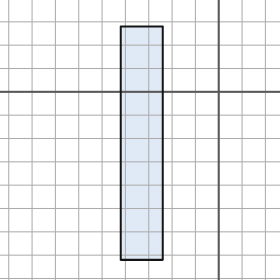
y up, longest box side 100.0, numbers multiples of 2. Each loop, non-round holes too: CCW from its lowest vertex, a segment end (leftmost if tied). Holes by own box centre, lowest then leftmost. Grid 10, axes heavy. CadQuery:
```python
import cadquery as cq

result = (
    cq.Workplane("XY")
    .moveTo(-42.0, -72.0)
    .lineTo(-24.0, -72.0)
    .lineTo(-24.0, 28.0)
    .lineTo(-42.0, 28.0)
    .close()
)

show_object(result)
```